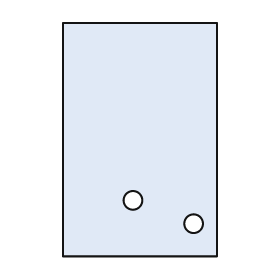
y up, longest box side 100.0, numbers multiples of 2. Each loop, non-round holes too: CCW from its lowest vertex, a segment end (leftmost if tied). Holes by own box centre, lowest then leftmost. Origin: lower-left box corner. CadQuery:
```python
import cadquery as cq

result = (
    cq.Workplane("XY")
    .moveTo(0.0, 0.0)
    .lineTo(66.0, 0.0)
    .lineTo(66.0, 100.0)
    .lineTo(0.0, 100.0)
    .close()
    .moveTo(56.0, 14.0)
    .circle(4.0)
    .moveTo(30.0, 24.0)
    .circle(4.0)
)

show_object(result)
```